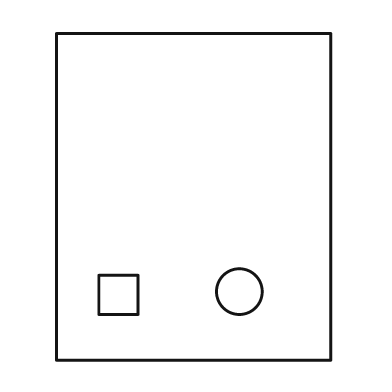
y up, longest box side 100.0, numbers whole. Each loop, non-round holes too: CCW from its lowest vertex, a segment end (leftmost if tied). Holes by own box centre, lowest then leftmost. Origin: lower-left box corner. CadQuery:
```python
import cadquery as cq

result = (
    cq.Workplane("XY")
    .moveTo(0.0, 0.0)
    .lineTo(84.0, 0.0)
    .lineTo(84.0, 100.0)
    .lineTo(0.0, 100.0)
    .close()
    .moveTo(13.0, 14.0)
    .lineTo(25.0, 14.0)
    .lineTo(25.0, 26.0)
    .lineTo(13.0, 26.0)
    .close()
    .moveTo(56.0, 21.0)
    .circle(7.0)
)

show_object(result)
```